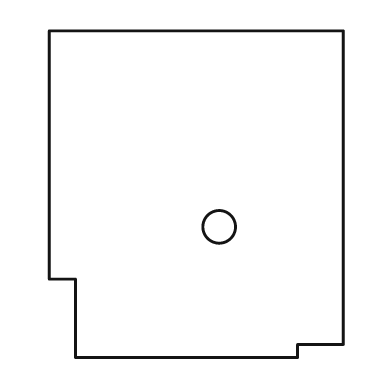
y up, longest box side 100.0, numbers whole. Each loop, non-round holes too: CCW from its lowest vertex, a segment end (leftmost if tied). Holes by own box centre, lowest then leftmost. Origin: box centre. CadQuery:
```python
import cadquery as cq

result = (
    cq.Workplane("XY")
    .moveTo(-37.0, -50.0)
    .lineTo(31.0, -50.0)
    .lineTo(31.0, -46.0)
    .lineTo(45.0, -46.0)
    .lineTo(45.0, 50.0)
    .lineTo(-45.0, 50.0)
    .lineTo(-45.0, -26.0)
    .lineTo(-37.0, -26.0)
    .close()
    .moveTo(7.0, -10.0)
    .circle(5.0)
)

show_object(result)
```